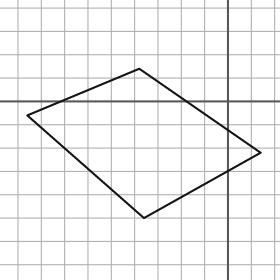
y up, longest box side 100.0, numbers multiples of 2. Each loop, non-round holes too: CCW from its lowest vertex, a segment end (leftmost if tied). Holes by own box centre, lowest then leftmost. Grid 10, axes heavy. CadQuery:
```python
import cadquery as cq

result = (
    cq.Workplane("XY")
    .moveTo(-36.0, -50.0)
    .lineTo(14.0, -22.0)
    .lineTo(-38.0, 14.0)
    .lineTo(-86.0, -6.0)
    .close()
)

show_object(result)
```